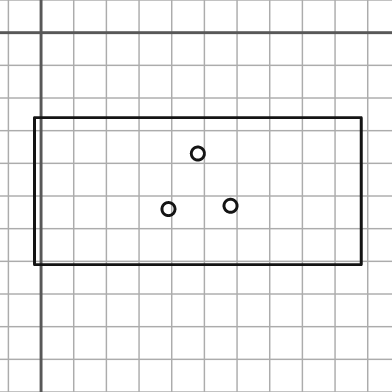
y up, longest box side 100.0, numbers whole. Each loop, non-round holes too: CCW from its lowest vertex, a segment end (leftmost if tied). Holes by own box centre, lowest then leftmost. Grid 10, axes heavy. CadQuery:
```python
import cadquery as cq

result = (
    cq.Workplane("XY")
    .moveTo(-2.0, -71.0)
    .lineTo(98.0, -71.0)
    .lineTo(98.0, -26.0)
    .lineTo(-2.0, -26.0)
    .close()
    .moveTo(39.0, -54.0)
    .circle(2.0)
    .moveTo(58.0, -53.0)
    .circle(2.0)
    .moveTo(48.0, -37.0)
    .circle(2.0)
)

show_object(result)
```